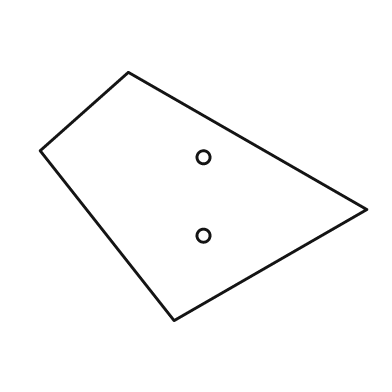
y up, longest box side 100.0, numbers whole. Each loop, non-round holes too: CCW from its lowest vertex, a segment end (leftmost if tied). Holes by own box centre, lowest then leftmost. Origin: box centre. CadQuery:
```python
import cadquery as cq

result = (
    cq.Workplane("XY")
    .moveTo(-9.0, -38.0)
    .lineTo(50.0, -4.0)
    .lineTo(-23.0, 38.0)
    .lineTo(-50.0, 14.0)
    .close()
    .moveTo(0.0, -12.0)
    .circle(2.0)
    .moveTo(0.0, 12.0)
    .circle(2.0)
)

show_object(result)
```